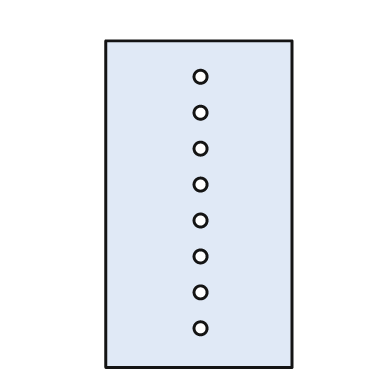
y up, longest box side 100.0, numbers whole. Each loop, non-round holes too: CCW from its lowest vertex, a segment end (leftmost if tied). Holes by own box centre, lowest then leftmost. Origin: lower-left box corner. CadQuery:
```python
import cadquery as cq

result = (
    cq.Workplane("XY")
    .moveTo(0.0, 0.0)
    .lineTo(57.0, 0.0)
    .lineTo(57.0, 100.0)
    .lineTo(0.0, 100.0)
    .close()
    .moveTo(29.0, 12.0)
    .circle(2.0)
    .moveTo(29.0, 23.0)
    .circle(2.0)
    .moveTo(29.0, 34.0)
    .circle(2.0)
    .moveTo(29.0, 45.0)
    .circle(2.0)
    .moveTo(29.0, 56.0)
    .circle(2.0)
    .moveTo(29.0, 67.0)
    .circle(2.0)
    .moveTo(29.0, 78.0)
    .circle(2.0)
    .moveTo(29.0, 89.0)
    .circle(2.0)
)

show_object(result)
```